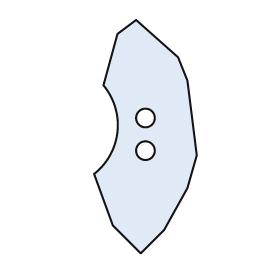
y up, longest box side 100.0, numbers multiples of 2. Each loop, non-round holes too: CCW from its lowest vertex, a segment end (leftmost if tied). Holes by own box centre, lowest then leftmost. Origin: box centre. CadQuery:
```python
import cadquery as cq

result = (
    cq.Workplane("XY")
    .moveTo(-2.0, -50.0)
    .lineTo(8.0, -40.0)
    .lineTo(18.0, -22.0)
    .lineTo(22.0, -8.0)
    .lineTo(18.0, 24.0)
    .lineTo(14.0, 34.0)
    .lineTo(-4.0, 50.0)
    .lineTo(-12.0, 44.0)
    .lineTo(-18.0, 22.0)
    .threePointArc((-12.0, 2.0), (-22.0, -16.0))
    .lineTo(-14.0, -38.0)
    .close()
    .moveTo(0.0, -6.0)
    .circle(4.0)
    .moveTo(0.0, 8.0)
    .circle(4.0)
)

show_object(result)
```